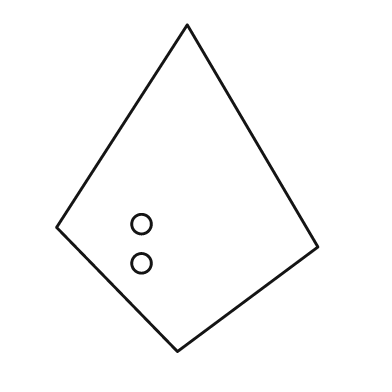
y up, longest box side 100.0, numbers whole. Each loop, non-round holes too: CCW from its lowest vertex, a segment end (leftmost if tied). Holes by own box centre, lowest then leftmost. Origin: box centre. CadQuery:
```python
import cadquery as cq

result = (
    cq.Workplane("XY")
    .moveTo(-3.0, -50.0)
    .lineTo(40.0, -18.0)
    .lineTo(0.0, 50.0)
    .lineTo(-40.0, -12.0)
    .close()
    .moveTo(-14.0, -23.0)
    .circle(3.0)
    .moveTo(-14.0, -11.0)
    .circle(3.0)
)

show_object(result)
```